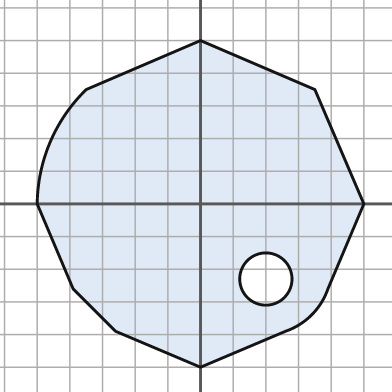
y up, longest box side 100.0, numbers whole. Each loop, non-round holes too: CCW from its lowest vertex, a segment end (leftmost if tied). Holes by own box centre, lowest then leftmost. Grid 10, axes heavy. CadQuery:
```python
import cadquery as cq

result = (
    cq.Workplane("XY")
    .moveTo(0.0, -50.0)
    .lineTo(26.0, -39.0)
    .threePointArc((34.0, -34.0), (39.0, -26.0))
    .lineTo(50.0, 0.0)
    .lineTo(35.0, 35.0)
    .lineTo(0.0, 50.0)
    .lineTo(-35.0, 35.0)
    .threePointArc((-46.0, 19.0), (-50.0, 0.0))
    .lineTo(-39.0, -26.0)
    .lineTo(-26.0, -39.0)
    .close()
    .moveTo(20.0, -23.0)
    .circle(8.0)
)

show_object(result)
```